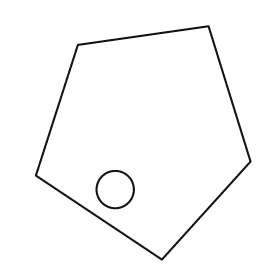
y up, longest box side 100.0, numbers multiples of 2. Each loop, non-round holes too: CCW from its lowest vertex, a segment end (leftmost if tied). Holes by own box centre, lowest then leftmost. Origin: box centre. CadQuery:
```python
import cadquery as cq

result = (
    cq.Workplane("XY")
    .moveTo(8.0, -50.0)
    .lineTo(46.0, -8.0)
    .lineTo(28.0, 50.0)
    .lineTo(-28.0, 42.0)
    .lineTo(-46.0, -14.0)
    .close()
    .moveTo(-12.0, -20.0)
    .circle(8.0)
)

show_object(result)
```